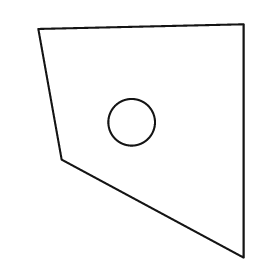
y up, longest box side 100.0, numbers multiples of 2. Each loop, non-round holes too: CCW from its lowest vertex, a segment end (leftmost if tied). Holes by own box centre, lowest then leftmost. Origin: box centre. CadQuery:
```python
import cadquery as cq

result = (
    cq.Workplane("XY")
    .moveTo(44.0, -50.0)
    .lineTo(44.0, 50.0)
    .lineTo(-44.0, 48.0)
    .lineTo(-34.0, -8.0)
    .close()
    .moveTo(-4.0, 8.0)
    .circle(10.0)
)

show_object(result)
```